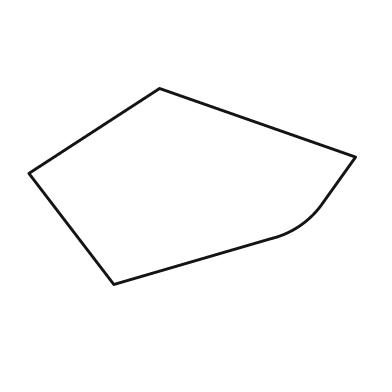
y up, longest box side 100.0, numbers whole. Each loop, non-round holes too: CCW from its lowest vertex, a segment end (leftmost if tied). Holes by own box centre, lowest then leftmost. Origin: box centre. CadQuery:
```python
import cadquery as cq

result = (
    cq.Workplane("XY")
    .moveTo(-24.0, -30.0)
    .lineTo(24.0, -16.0)
    .threePointArc((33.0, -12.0), (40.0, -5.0))
    .lineTo(50.0, 9.0)
    .lineTo(-10.0, 30.0)
    .lineTo(-50.0, 4.0)
    .close()
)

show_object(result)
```